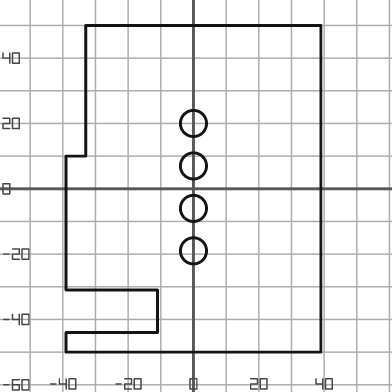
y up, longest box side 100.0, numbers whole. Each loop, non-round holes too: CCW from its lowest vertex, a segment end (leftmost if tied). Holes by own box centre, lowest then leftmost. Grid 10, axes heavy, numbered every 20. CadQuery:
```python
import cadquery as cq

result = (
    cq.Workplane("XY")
    .moveTo(-39.0, -50.0)
    .lineTo(39.0, -50.0)
    .lineTo(39.0, 50.0)
    .lineTo(-33.0, 50.0)
    .lineTo(-33.0, 10.0)
    .lineTo(-39.0, 10.0)
    .lineTo(-39.0, -31.0)
    .lineTo(-11.0, -31.0)
    .lineTo(-11.0, -44.0)
    .lineTo(-39.0, -44.0)
    .close()
    .moveTo(0.0, -19.0)
    .circle(4.0)
    .moveTo(0.0, -6.0)
    .circle(4.0)
    .moveTo(0.0, 7.0)
    .circle(4.0)
    .moveTo(0.0, 20.0)
    .circle(4.0)
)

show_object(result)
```